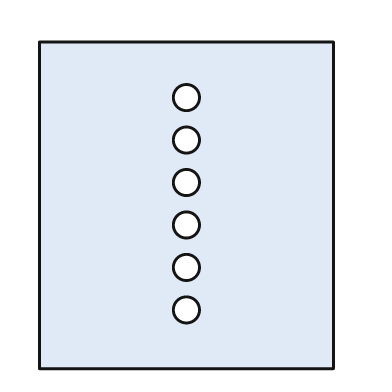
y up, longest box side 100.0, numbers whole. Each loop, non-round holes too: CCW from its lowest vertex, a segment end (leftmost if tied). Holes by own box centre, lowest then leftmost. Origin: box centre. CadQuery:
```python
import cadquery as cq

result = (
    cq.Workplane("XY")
    .moveTo(-45.0, -50.0)
    .lineTo(45.0, -50.0)
    .lineTo(45.0, 50.0)
    .lineTo(-45.0, 50.0)
    .close()
    .moveTo(0.0, -32.0)
    .circle(4.0)
    .moveTo(0.0, -19.0)
    .circle(4.0)
    .moveTo(0.0, -6.0)
    .circle(4.0)
    .moveTo(0.0, 7.0)
    .circle(4.0)
    .moveTo(0.0, 20.0)
    .circle(4.0)
    .moveTo(0.0, 33.0)
    .circle(4.0)
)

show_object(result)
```